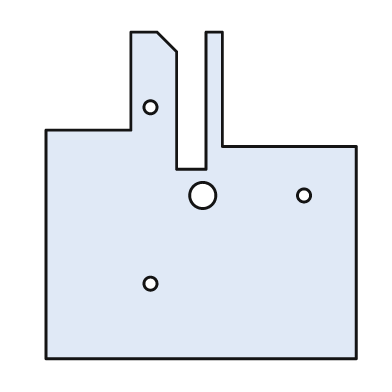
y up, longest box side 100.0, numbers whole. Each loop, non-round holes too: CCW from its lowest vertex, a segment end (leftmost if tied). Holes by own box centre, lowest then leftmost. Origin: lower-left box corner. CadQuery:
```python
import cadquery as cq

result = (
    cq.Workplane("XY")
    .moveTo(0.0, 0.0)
    .lineTo(95.0, 0.0)
    .lineTo(95.0, 65.0)
    .lineTo(54.0, 65.0)
    .lineTo(54.0, 100.0)
    .lineTo(49.0, 100.0)
    .lineTo(49.0, 58.0)
    .lineTo(40.0, 58.0)
    .lineTo(40.0, 94.0)
    .lineTo(34.0, 100.0)
    .lineTo(26.0, 100.0)
    .lineTo(26.0, 70.0)
    .lineTo(0.0, 70.0)
    .close()
    .moveTo(32.0, 23.0)
    .circle(2.0)
    .moveTo(48.0, 50.0)
    .circle(4.0)
    .moveTo(79.0, 50.0)
    .circle(2.0)
    .moveTo(32.0, 77.0)
    .circle(2.0)
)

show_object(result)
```